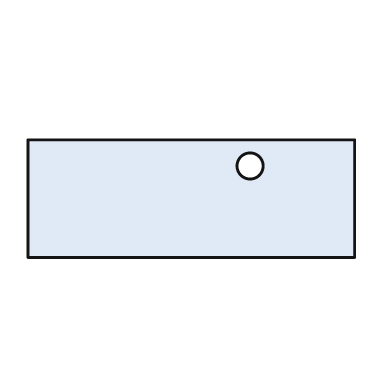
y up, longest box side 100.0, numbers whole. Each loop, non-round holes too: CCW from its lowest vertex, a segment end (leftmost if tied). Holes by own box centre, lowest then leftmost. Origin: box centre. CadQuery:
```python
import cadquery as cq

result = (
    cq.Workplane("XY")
    .moveTo(-50.0, -18.0)
    .lineTo(50.0, -18.0)
    .lineTo(50.0, 18.0)
    .lineTo(-50.0, 18.0)
    .close()
    .moveTo(18.0, 10.0)
    .circle(4.0)
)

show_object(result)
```